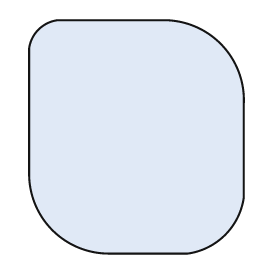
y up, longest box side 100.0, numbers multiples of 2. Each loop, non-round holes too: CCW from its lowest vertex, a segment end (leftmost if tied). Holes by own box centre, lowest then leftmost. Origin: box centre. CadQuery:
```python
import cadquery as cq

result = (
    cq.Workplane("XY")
    .moveTo(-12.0, -50.0)
    .lineTo(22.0, -50.0)
    .threePointArc((38.0, -42.0), (46.0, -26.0))
    .lineTo(46.0, 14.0)
    .threePointArc((36.0, 40.0), (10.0, 50.0))
    .lineTo(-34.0, 50.0)
    .threePointArc((-42.0, 46.0), (-46.0, 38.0))
    .lineTo(-46.0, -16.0)
    .threePointArc((-36.0, -40.0), (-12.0, -50.0))
    .close()
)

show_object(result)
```